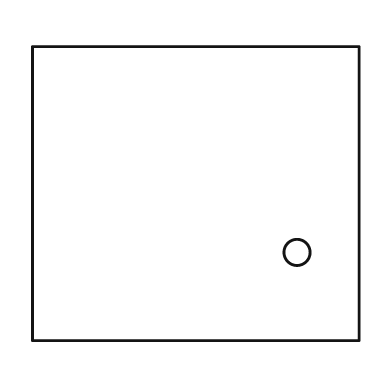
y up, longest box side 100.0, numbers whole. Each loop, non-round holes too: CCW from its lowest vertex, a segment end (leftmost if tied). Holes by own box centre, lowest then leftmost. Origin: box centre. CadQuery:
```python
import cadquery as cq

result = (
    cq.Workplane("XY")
    .moveTo(-50.0, -45.0)
    .lineTo(50.0, -45.0)
    .lineTo(50.0, 45.0)
    .lineTo(-50.0, 45.0)
    .close()
    .moveTo(31.0, -18.0)
    .circle(4.0)
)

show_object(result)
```